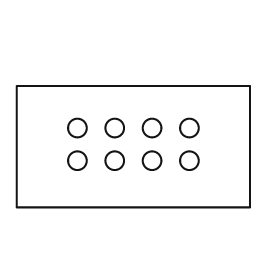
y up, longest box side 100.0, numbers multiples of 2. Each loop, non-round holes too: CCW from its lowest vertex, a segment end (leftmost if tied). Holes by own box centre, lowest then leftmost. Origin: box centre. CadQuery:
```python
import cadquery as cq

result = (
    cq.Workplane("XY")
    .moveTo(-50.0, -26.0)
    .lineTo(50.0, -26.0)
    .lineTo(50.0, 26.0)
    .lineTo(-50.0, 26.0)
    .close()
    .moveTo(-24.0, -6.0)
    .circle(4.0)
    .moveTo(-8.0, -6.0)
    .circle(4.0)
    .moveTo(8.0, -6.0)
    .circle(4.0)
    .moveTo(24.0, -6.0)
    .circle(4.0)
    .moveTo(-24.0, 8.0)
    .circle(4.0)
    .moveTo(-8.0, 8.0)
    .circle(4.0)
    .moveTo(8.0, 8.0)
    .circle(4.0)
    .moveTo(24.0, 8.0)
    .circle(4.0)
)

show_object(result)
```